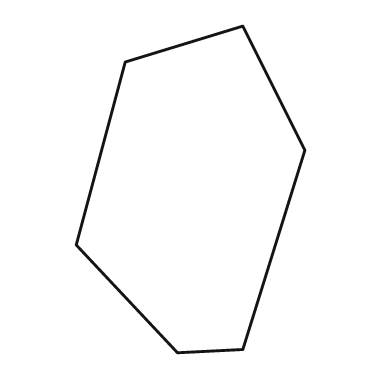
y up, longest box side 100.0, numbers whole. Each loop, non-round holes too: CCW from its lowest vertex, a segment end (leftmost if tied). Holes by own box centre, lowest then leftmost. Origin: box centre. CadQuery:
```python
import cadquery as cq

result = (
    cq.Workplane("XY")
    .moveTo(-4.0, -50.0)
    .lineTo(16.0, -49.0)
    .lineTo(35.0, 12.0)
    .lineTo(16.0, 50.0)
    .lineTo(-20.0, 39.0)
    .lineTo(-35.0, -17.0)
    .close()
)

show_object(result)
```